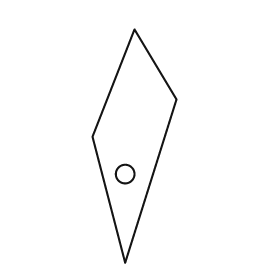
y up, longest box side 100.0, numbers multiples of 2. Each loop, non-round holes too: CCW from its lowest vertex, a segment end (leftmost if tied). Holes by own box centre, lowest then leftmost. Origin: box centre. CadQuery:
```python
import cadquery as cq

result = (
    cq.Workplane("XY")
    .moveTo(-4.0, -50.0)
    .lineTo(18.0, 20.0)
    .lineTo(0.0, 50.0)
    .lineTo(-18.0, 4.0)
    .close()
    .moveTo(-4.0, -12.0)
    .circle(4.0)
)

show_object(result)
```